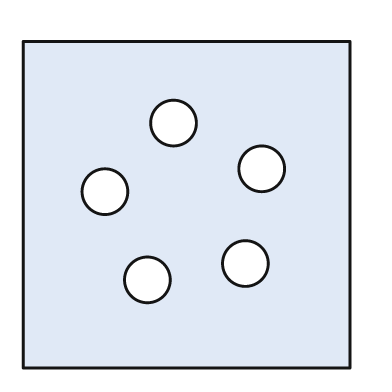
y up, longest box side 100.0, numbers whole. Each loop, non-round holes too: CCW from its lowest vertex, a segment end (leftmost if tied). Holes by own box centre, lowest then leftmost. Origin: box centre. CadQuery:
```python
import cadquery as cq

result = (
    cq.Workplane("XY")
    .moveTo(-50.0, -50.0)
    .lineTo(50.0, -50.0)
    .lineTo(50.0, 50.0)
    .lineTo(-50.0, 50.0)
    .close()
    .moveTo(-12.0, -23.0)
    .circle(7.0)
    .moveTo(18.0, -18.0)
    .circle(7.0)
    .moveTo(-25.0, 4.0)
    .circle(7.0)
    .moveTo(23.0, 11.0)
    .circle(7.0)
    .moveTo(-4.0, 25.0)
    .circle(7.0)
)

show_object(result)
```